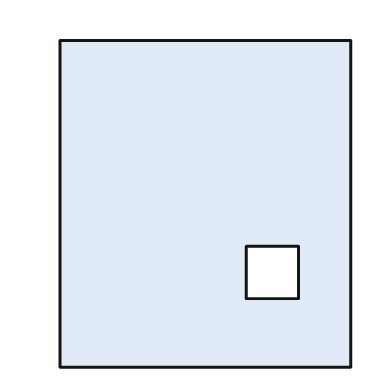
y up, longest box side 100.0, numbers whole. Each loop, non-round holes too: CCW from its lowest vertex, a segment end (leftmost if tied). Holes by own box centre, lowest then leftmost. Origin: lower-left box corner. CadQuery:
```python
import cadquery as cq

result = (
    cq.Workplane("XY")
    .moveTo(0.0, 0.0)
    .lineTo(89.0, 0.0)
    .lineTo(89.0, 100.0)
    .lineTo(0.0, 100.0)
    .close()
    .moveTo(57.0, 21.0)
    .lineTo(73.0, 21.0)
    .lineTo(73.0, 37.0)
    .lineTo(57.0, 37.0)
    .close()
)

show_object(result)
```